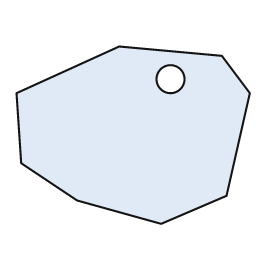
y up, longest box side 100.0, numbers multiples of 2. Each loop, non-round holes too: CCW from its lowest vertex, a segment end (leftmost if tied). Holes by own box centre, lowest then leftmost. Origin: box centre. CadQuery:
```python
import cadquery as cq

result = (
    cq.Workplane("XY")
    .moveTo(12.0, -38.0)
    .lineTo(40.0, -26.0)
    .lineTo(50.0, 18.0)
    .lineTo(38.0, 34.0)
    .lineTo(-6.0, 38.0)
    .lineTo(-50.0, 18.0)
    .lineTo(-48.0, -12.0)
    .lineTo(-24.0, -28.0)
    .close()
    .moveTo(16.0, 24.0)
    .circle(6.0)
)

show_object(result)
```